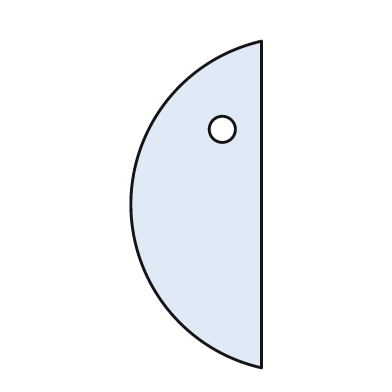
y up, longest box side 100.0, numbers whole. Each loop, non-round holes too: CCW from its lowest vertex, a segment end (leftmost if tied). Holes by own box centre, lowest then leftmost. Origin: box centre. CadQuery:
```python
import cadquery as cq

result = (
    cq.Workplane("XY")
    .moveTo(20.0, -50.0)
    .lineTo(20.0, 50.0)
    .threePointArc((-20.0, 0.0), (20.0, -50.0))
    .close()
    .moveTo(8.0, 23.0)
    .circle(4.0)
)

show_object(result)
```